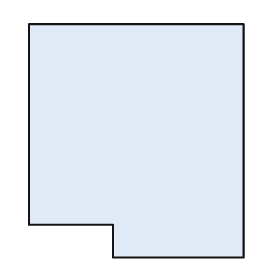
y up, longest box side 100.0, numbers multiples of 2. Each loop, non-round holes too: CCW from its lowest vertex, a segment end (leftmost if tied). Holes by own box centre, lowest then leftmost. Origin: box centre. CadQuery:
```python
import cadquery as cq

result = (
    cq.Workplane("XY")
    .moveTo(-10.0, -50.0)
    .lineTo(46.0, -50.0)
    .lineTo(46.0, 50.0)
    .lineTo(-46.0, 50.0)
    .lineTo(-46.0, -36.0)
    .lineTo(-10.0, -36.0)
    .close()
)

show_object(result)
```